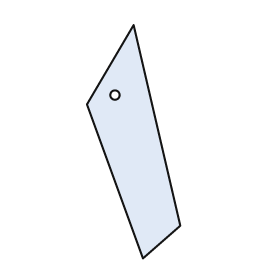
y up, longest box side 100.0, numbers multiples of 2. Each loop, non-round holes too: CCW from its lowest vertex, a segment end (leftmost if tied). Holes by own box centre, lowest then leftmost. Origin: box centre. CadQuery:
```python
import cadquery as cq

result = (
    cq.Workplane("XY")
    .moveTo(4.0, -50.0)
    .lineTo(20.0, -36.0)
    .lineTo(0.0, 50.0)
    .lineTo(-20.0, 16.0)
    .close()
    .moveTo(-8.0, 20.0)
    .circle(2.0)
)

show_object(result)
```